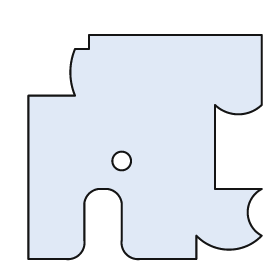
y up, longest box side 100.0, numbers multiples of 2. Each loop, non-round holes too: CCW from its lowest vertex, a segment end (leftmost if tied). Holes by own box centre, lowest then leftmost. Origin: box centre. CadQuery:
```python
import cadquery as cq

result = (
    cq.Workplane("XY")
    .moveTo(-50.0, -48.0)
    .lineTo(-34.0, -48.0)
    .threePointArc((-28.0, -46.0), (-26.0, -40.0))
    .lineTo(-26.0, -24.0)
    .threePointArc((-24.0, -20.0), (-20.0, -18.0))
    .lineTo(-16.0, -18.0)
    .threePointArc((-12.0, -20.0), (-10.0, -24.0))
    .lineTo(-10.0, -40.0)
    .threePointArc((-8.0, -46.0), (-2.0, -48.0))
    .lineTo(22.0, -48.0)
    .lineTo(22.0, -38.0)
    .threePointArc((36.0, -44.0), (50.0, -38.0))
    .threePointArc((44.0, -28.0), (50.0, -18.0))
    .lineTo(30.0, -18.0)
    .lineTo(30.0, 18.0)
    .threePointArc((40.0, 14.0), (50.0, 18.0))
    .lineTo(50.0, 48.0)
    .lineTo(-24.0, 48.0)
    .lineTo(-24.0, 42.0)
    .lineTo(-30.0, 42.0)
    .threePointArc((-32.0, 32.0), (-30.0, 22.0))
    .lineTo(-50.0, 22.0)
    .close()
    .moveTo(-10.0, -6.0)
    .circle(4.0)
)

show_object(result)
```